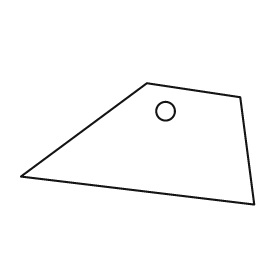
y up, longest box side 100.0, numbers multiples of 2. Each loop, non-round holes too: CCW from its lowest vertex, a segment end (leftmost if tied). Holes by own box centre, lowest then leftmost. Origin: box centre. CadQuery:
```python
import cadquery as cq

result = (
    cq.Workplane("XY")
    .moveTo(50.0, -26.0)
    .lineTo(44.0, 20.0)
    .lineTo(4.0, 26.0)
    .lineTo(-50.0, -14.0)
    .close()
    .moveTo(12.0, 14.0)
    .circle(4.0)
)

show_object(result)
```